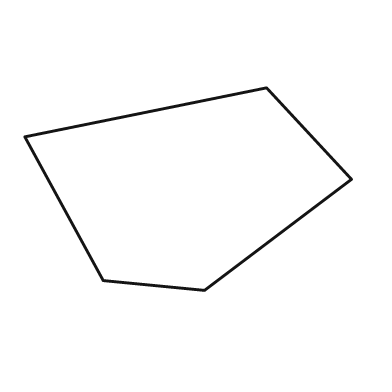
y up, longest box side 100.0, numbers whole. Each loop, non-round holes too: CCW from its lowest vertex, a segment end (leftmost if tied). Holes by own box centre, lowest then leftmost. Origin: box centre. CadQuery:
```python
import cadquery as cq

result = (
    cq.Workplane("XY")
    .moveTo(5.0, -31.0)
    .lineTo(50.0, 3.0)
    .lineTo(24.0, 31.0)
    .lineTo(-50.0, 16.0)
    .lineTo(-26.0, -28.0)
    .close()
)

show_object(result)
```